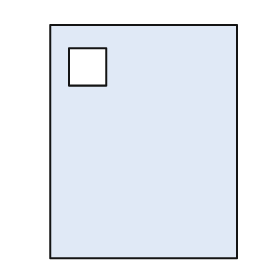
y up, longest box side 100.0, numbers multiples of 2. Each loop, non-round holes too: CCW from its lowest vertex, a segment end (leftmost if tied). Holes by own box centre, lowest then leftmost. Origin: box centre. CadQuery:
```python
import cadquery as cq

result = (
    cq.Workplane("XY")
    .moveTo(-40.0, -50.0)
    .lineTo(40.0, -50.0)
    .lineTo(40.0, 50.0)
    .lineTo(-40.0, 50.0)
    .close()
    .moveTo(-32.0, 24.0)
    .lineTo(-16.0, 24.0)
    .lineTo(-16.0, 40.0)
    .lineTo(-32.0, 40.0)
    .close()
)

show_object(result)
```